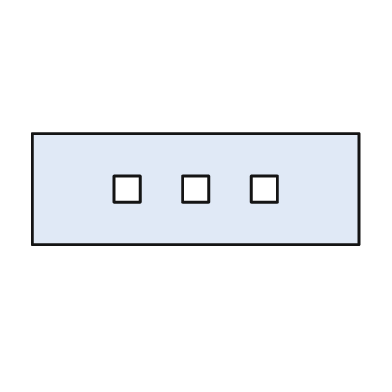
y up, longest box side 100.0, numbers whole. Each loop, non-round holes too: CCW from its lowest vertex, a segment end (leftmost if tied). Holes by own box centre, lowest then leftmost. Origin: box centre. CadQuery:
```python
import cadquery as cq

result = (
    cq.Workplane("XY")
    .moveTo(-50.0, -17.0)
    .lineTo(50.0, -17.0)
    .lineTo(50.0, 17.0)
    .lineTo(-50.0, 17.0)
    .close()
    .moveTo(-25.0, -4.0)
    .lineTo(-17.0, -4.0)
    .lineTo(-17.0, 4.0)
    .lineTo(-25.0, 4.0)
    .close()
    .moveTo(-4.0, -4.0)
    .lineTo(4.0, -4.0)
    .lineTo(4.0, 4.0)
    .lineTo(-4.0, 4.0)
    .close()
    .moveTo(17.0, -4.0)
    .lineTo(25.0, -4.0)
    .lineTo(25.0, 4.0)
    .lineTo(17.0, 4.0)
    .close()
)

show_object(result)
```